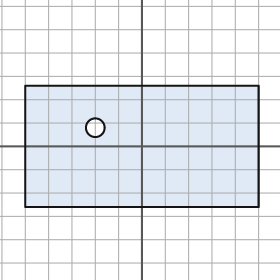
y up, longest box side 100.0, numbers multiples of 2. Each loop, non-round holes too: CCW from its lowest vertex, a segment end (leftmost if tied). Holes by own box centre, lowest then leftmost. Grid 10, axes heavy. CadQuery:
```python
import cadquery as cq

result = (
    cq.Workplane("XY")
    .moveTo(-50.0, -26.0)
    .lineTo(50.0, -26.0)
    .lineTo(50.0, 26.0)
    .lineTo(-50.0, 26.0)
    .close()
    .moveTo(-20.0, 8.0)
    .circle(4.0)
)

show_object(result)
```